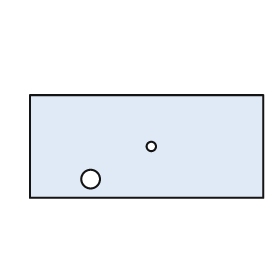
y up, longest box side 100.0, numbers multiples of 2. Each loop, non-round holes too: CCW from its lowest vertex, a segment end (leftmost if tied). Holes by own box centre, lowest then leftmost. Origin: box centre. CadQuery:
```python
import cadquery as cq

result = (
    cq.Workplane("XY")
    .moveTo(-50.0, -22.0)
    .lineTo(50.0, -22.0)
    .lineTo(50.0, 22.0)
    .lineTo(-50.0, 22.0)
    .close()
    .moveTo(-24.0, -14.0)
    .circle(4.0)
    .moveTo(2.0, 0.0)
    .circle(2.0)
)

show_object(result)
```